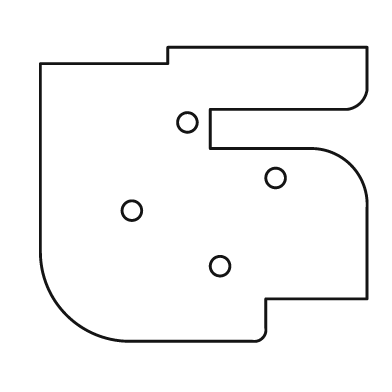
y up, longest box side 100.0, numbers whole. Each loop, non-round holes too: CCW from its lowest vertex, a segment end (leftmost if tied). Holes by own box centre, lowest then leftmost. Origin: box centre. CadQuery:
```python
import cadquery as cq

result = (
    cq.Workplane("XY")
    .moveTo(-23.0, -45.0)
    .lineTo(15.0, -45.0)
    .threePointArc((18.0, -44.0), (19.0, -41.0))
    .lineTo(19.0, -32.0)
    .lineTo(50.0, -32.0)
    .lineTo(50.0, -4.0)
    .threePointArc((45.0, 9.0), (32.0, 14.0))
    .lineTo(2.0, 14.0)
    .lineTo(2.0, 26.0)
    .lineTo(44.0, 26.0)
    .threePointArc((48.0, 28.0), (50.0, 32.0))
    .lineTo(50.0, 45.0)
    .lineTo(-11.0, 45.0)
    .lineTo(-11.0, 40.0)
    .lineTo(-50.0, 40.0)
    .lineTo(-50.0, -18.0)
    .threePointArc((-42.0, -37.0), (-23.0, -45.0))
    .close()
    .moveTo(5.0, -22.0)
    .circle(3.0)
    .moveTo(-22.0, -5.0)
    .circle(3.0)
    .moveTo(22.0, 5.0)
    .circle(3.0)
    .moveTo(-5.0, 22.0)
    .circle(3.0)
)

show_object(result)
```